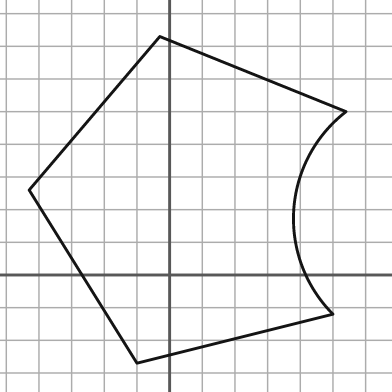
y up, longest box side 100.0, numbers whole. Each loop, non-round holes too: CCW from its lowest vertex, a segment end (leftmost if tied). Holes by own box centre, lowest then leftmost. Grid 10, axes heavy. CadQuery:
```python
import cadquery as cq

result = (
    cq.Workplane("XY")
    .moveTo(-10.0, -27.0)
    .lineTo(50.0, -12.0)
    .threePointArc((38.0, 20.0), (54.0, 50.0))
    .lineTo(-3.0, 73.0)
    .lineTo(-43.0, 26.0)
    .close()
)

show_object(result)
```